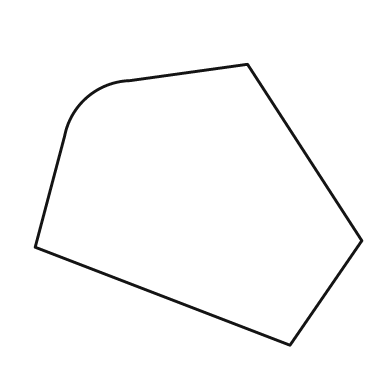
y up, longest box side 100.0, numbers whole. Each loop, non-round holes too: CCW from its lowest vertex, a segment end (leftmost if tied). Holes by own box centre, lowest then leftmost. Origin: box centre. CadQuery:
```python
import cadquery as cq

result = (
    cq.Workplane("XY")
    .moveTo(28.0, -43.0)
    .lineTo(50.0, -11.0)
    .lineTo(15.0, 43.0)
    .lineTo(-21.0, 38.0)
    .threePointArc((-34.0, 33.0), (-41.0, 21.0))
    .lineTo(-50.0, -13.0)
    .close()
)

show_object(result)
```